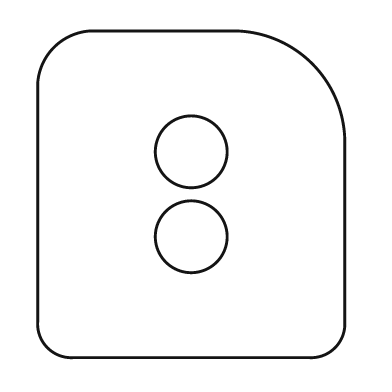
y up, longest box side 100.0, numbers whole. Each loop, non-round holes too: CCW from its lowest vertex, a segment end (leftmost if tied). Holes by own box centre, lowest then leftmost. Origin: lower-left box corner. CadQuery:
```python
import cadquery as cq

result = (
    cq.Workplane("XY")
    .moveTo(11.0, 0.0)
    .lineTo(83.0, 0.0)
    .threePointArc((91.0, 3.0), (94.0, 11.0))
    .lineTo(94.0, 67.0)
    .threePointArc((84.0, 90.0), (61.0, 100.0))
    .lineTo(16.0, 100.0)
    .threePointArc((5.0, 95.0), (0.0, 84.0))
    .lineTo(0.0, 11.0)
    .threePointArc((3.0, 3.0), (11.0, 0.0))
    .close()
    .moveTo(47.0, 37.0)
    .circle(11.0)
    .moveTo(47.0, 63.0)
    .circle(11.0)
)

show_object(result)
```